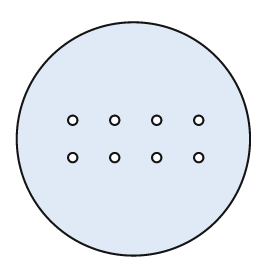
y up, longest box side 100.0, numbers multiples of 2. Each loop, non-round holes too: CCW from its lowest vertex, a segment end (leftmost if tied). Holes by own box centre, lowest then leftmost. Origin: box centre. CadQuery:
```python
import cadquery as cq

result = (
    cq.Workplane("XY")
    .moveTo(0.0, 0.0)
    .circle(50.0)
    .moveTo(-26.0, -8.0)
    .circle(2.0)
    .moveTo(-8.0, -8.0)
    .circle(2.0)
    .moveTo(10.0, -8.0)
    .circle(2.0)
    .moveTo(28.0, -8.0)
    .circle(2.0)
    .moveTo(-26.0, 8.0)
    .circle(2.0)
    .moveTo(-8.0, 8.0)
    .circle(2.0)
    .moveTo(10.0, 8.0)
    .circle(2.0)
    .moveTo(28.0, 8.0)
    .circle(2.0)
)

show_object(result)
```